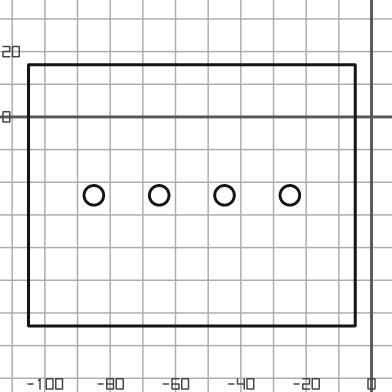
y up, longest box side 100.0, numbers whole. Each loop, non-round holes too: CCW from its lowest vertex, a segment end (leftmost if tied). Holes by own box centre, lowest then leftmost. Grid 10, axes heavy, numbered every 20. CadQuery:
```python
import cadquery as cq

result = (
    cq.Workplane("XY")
    .moveTo(-105.0, -64.0)
    .lineTo(-5.0, -64.0)
    .lineTo(-5.0, 16.0)
    .lineTo(-105.0, 16.0)
    .close()
    .moveTo(-85.0, -24.0)
    .circle(3.0)
    .moveTo(-65.0, -24.0)
    .circle(3.0)
    .moveTo(-45.0, -24.0)
    .circle(3.0)
    .moveTo(-25.0, -24.0)
    .circle(3.0)
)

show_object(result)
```